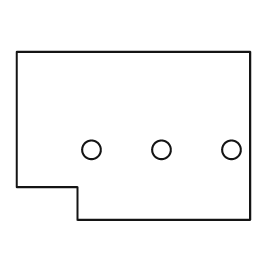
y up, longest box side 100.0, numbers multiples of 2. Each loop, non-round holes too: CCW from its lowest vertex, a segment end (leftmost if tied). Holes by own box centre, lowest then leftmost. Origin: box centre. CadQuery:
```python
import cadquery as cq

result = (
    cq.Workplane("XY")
    .moveTo(-24.0, -36.0)
    .lineTo(50.0, -36.0)
    .lineTo(50.0, 36.0)
    .lineTo(-50.0, 36.0)
    .lineTo(-50.0, -22.0)
    .lineTo(-24.0, -22.0)
    .close()
    .moveTo(-18.0, -6.0)
    .circle(4.0)
    .moveTo(12.0, -6.0)
    .circle(4.0)
    .moveTo(42.0, -6.0)
    .circle(4.0)
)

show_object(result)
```